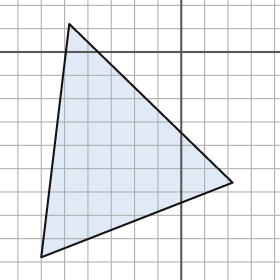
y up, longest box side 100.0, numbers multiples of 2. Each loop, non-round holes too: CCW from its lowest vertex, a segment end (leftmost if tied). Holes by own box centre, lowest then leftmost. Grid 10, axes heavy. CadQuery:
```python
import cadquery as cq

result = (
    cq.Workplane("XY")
    .moveTo(-60.0, -88.0)
    .lineTo(22.0, -56.0)
    .lineTo(-48.0, 12.0)
    .close()
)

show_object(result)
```